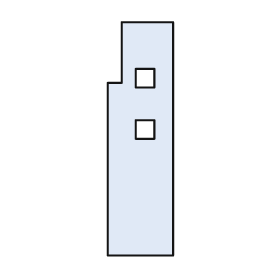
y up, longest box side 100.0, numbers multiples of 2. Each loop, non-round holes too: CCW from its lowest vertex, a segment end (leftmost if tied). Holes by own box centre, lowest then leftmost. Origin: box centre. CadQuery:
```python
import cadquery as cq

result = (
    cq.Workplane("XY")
    .moveTo(-14.0, -50.0)
    .lineTo(14.0, -50.0)
    .lineTo(14.0, 50.0)
    .lineTo(-8.0, 50.0)
    .lineTo(-8.0, 24.0)
    .lineTo(-14.0, 24.0)
    .close()
    .moveTo(-2.0, 0.0)
    .lineTo(6.0, 0.0)
    .lineTo(6.0, 8.0)
    .lineTo(-2.0, 8.0)
    .close()
    .moveTo(-2.0, 22.0)
    .lineTo(6.0, 22.0)
    .lineTo(6.0, 30.0)
    .lineTo(-2.0, 30.0)
    .close()
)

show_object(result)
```